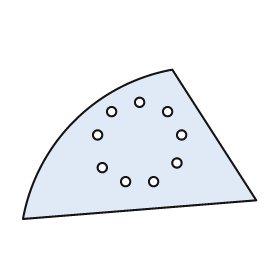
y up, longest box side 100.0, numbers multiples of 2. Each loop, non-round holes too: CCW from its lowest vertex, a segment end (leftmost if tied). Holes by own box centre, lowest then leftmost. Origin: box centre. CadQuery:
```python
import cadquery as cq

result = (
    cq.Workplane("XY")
    .moveTo(-50.0, -32.0)
    .lineTo(50.0, -24.0)
    .lineTo(14.0, 32.0)
    .threePointArc((-28.0, 10.0), (-50.0, -32.0))
    .close()
    .moveTo(-6.0, -16.0)
    .circle(2.0)
    .moveTo(6.0, -16.0)
    .circle(2.0)
    .moveTo(-16.0, -10.0)
    .circle(2.0)
    .moveTo(16.0, -8.0)
    .circle(2.0)
    .moveTo(-18.0, 4.0)
    .circle(2.0)
    .moveTo(18.0, 4.0)
    .circle(2.0)
    .moveTo(-12.0, 14.0)
    .circle(2.0)
    .moveTo(12.0, 14.0)
    .circle(2.0)
    .moveTo(0.0, 18.0)
    .circle(2.0)
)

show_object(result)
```